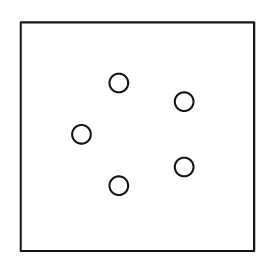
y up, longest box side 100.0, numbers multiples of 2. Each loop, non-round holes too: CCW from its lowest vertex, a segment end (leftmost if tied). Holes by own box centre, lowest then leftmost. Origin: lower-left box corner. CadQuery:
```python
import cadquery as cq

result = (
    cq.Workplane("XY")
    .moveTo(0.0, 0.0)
    .lineTo(100.0, 0.0)
    .lineTo(100.0, 98.0)
    .lineTo(0.0, 98.0)
    .close()
    .moveTo(42.0, 28.0)
    .circle(4.0)
    .moveTo(70.0, 36.0)
    .circle(4.0)
    .moveTo(26.0, 50.0)
    .circle(4.0)
    .moveTo(70.0, 64.0)
    .circle(4.0)
    .moveTo(42.0, 72.0)
    .circle(4.0)
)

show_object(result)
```